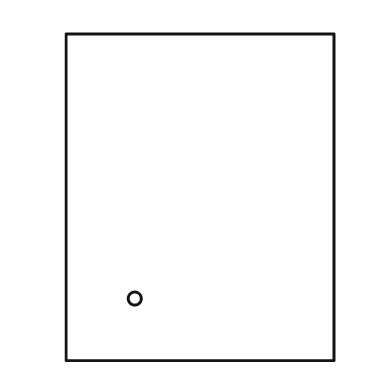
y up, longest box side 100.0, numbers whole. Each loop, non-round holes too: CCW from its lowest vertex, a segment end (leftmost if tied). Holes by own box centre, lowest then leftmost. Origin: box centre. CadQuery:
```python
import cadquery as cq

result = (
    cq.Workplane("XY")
    .moveTo(-41.0, -50.0)
    .lineTo(41.0, -50.0)
    .lineTo(41.0, 50.0)
    .lineTo(-41.0, 50.0)
    .close()
    .moveTo(-20.0, -31.0)
    .circle(2.0)
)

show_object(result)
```